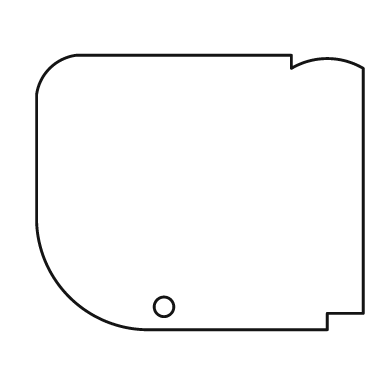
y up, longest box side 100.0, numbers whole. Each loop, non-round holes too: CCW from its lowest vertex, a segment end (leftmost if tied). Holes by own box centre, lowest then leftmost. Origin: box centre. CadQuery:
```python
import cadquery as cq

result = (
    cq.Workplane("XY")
    .moveTo(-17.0, -42.0)
    .lineTo(39.0, -42.0)
    .lineTo(39.0, -37.0)
    .lineTo(50.0, -37.0)
    .lineTo(50.0, 38.0)
    .threePointArc((39.0, 41.0), (28.0, 38.0))
    .lineTo(28.0, 42.0)
    .lineTo(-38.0, 42.0)
    .threePointArc((-46.0, 38.0), (-50.0, 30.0))
    .lineTo(-50.0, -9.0)
    .threePointArc((-40.0, -32.0), (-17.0, -42.0))
    .close()
    .moveTo(-11.0, -35.0)
    .circle(3.0)
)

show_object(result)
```